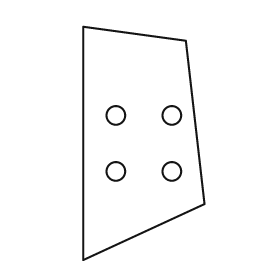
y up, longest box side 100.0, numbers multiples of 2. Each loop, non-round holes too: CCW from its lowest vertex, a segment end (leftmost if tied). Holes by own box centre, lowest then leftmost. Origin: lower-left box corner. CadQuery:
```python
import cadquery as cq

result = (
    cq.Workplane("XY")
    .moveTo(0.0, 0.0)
    .lineTo(52.0, 24.0)
    .lineTo(44.0, 94.0)
    .lineTo(0.0, 100.0)
    .close()
    .moveTo(14.0, 38.0)
    .circle(4.0)
    .moveTo(38.0, 38.0)
    .circle(4.0)
    .moveTo(14.0, 62.0)
    .circle(4.0)
    .moveTo(38.0, 62.0)
    .circle(4.0)
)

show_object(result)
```